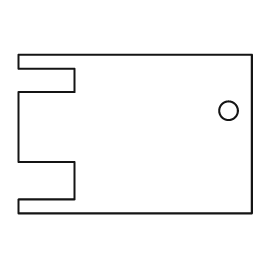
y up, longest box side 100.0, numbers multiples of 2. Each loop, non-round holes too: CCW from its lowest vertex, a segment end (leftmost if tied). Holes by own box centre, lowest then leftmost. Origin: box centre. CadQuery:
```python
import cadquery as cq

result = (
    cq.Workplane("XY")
    .moveTo(-50.0, -34.0)
    .lineTo(50.0, -34.0)
    .lineTo(50.0, 34.0)
    .lineTo(-50.0, 34.0)
    .lineTo(-50.0, 28.0)
    .lineTo(-26.0, 28.0)
    .lineTo(-26.0, 18.0)
    .lineTo(-50.0, 18.0)
    .lineTo(-50.0, -12.0)
    .lineTo(-26.0, -12.0)
    .lineTo(-26.0, -28.0)
    .lineTo(-50.0, -28.0)
    .close()
    .moveTo(40.0, 10.0)
    .circle(4.0)
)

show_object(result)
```